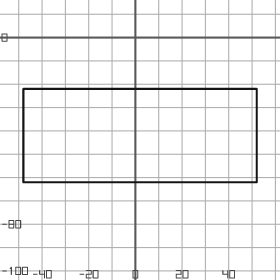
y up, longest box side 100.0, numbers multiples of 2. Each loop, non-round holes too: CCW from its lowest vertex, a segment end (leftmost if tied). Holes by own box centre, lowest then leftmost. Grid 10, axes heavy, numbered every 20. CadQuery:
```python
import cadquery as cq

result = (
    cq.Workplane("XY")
    .moveTo(-48.0, -62.0)
    .lineTo(52.0, -62.0)
    .lineTo(52.0, -22.0)
    .lineTo(-48.0, -22.0)
    .close()
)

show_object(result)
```